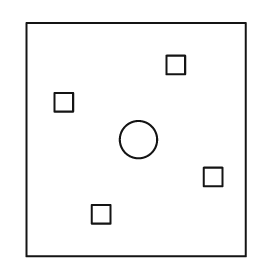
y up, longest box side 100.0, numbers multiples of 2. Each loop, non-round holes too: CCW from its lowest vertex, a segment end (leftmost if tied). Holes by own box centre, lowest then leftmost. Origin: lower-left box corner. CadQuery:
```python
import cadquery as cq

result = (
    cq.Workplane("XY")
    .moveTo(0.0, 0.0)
    .lineTo(94.0, 0.0)
    .lineTo(94.0, 100.0)
    .lineTo(0.0, 100.0)
    .close()
    .moveTo(28.0, 14.0)
    .lineTo(36.0, 14.0)
    .lineTo(36.0, 22.0)
    .lineTo(28.0, 22.0)
    .close()
    .moveTo(76.0, 30.0)
    .lineTo(84.0, 30.0)
    .lineTo(84.0, 38.0)
    .lineTo(76.0, 38.0)
    .close()
    .moveTo(48.0, 50.0)
    .circle(8.0)
    .moveTo(12.0, 62.0)
    .lineTo(20.0, 62.0)
    .lineTo(20.0, 70.0)
    .lineTo(12.0, 70.0)
    .close()
    .moveTo(60.0, 78.0)
    .lineTo(68.0, 78.0)
    .lineTo(68.0, 86.0)
    .lineTo(60.0, 86.0)
    .close()
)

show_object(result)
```